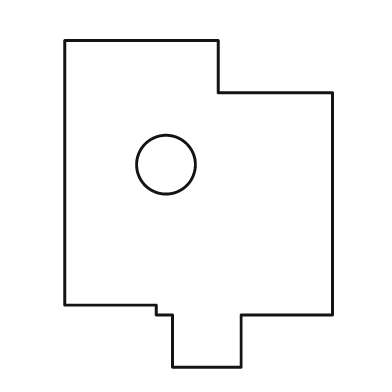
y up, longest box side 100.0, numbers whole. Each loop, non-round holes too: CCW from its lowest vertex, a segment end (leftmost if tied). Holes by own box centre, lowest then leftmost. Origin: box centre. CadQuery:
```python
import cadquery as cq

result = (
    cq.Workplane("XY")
    .moveTo(-8.0, -50.0)
    .lineTo(13.0, -50.0)
    .lineTo(13.0, -34.0)
    .lineTo(41.0, -34.0)
    .lineTo(41.0, 34.0)
    .lineTo(6.0, 34.0)
    .lineTo(6.0, 50.0)
    .lineTo(-41.0, 50.0)
    .lineTo(-41.0, -31.0)
    .lineTo(-13.0, -31.0)
    .lineTo(-13.0, -34.0)
    .lineTo(-8.0, -34.0)
    .close()
    .moveTo(-10.0, 12.0)
    .circle(9.0)
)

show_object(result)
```